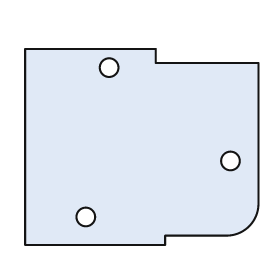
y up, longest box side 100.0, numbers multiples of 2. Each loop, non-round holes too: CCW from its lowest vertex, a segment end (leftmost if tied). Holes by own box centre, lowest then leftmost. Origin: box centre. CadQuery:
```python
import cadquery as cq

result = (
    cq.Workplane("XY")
    .moveTo(-50.0, -42.0)
    .lineTo(10.0, -42.0)
    .lineTo(10.0, -38.0)
    .lineTo(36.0, -38.0)
    .threePointArc((46.0, -34.0), (50.0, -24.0))
    .lineTo(50.0, 36.0)
    .lineTo(6.0, 36.0)
    .lineTo(6.0, 42.0)
    .lineTo(-50.0, 42.0)
    .close()
    .moveTo(-24.0, -30.0)
    .circle(4.0)
    .moveTo(38.0, -6.0)
    .circle(4.0)
    .moveTo(-14.0, 34.0)
    .circle(4.0)
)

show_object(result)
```